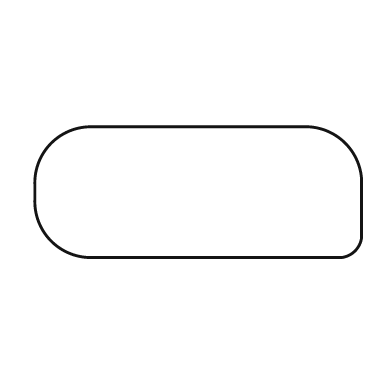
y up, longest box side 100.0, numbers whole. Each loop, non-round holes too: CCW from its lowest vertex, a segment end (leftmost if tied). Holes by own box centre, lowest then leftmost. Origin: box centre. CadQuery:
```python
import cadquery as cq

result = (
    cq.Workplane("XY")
    .moveTo(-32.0, -20.0)
    .lineTo(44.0, -20.0)
    .threePointArc((48.0, -18.0), (50.0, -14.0))
    .lineTo(50.0, 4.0)
    .threePointArc((45.0, 15.0), (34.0, 20.0))
    .lineTo(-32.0, 20.0)
    .threePointArc((-45.0, 15.0), (-50.0, 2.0))
    .lineTo(-50.0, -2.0)
    .threePointArc((-45.0, -15.0), (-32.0, -20.0))
    .close()
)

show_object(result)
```